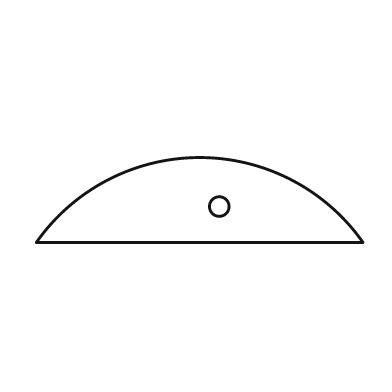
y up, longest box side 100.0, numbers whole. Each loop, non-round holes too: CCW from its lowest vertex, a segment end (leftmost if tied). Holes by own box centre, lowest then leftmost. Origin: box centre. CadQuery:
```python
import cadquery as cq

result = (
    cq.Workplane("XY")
    .moveTo(-50.0, -13.0)
    .lineTo(50.0, -13.0)
    .threePointArc((0.0, 13.0), (-50.0, -13.0))
    .close()
    .moveTo(6.0, -2.0)
    .circle(3.0)
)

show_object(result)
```